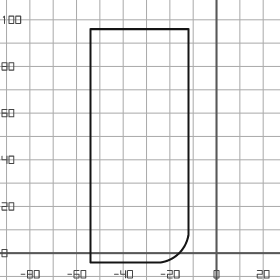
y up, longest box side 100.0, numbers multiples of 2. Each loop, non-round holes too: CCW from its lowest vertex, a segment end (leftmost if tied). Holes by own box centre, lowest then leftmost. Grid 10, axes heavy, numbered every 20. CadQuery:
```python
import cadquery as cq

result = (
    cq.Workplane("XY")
    .moveTo(-54.0, -4.0)
    .lineTo(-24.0, -4.0)
    .threePointArc((-16.0, 0.0), (-12.0, 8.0))
    .lineTo(-12.0, 96.0)
    .lineTo(-54.0, 96.0)
    .close()
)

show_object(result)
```